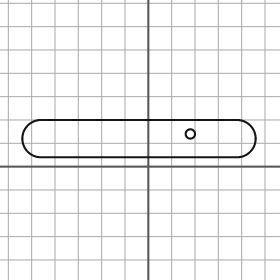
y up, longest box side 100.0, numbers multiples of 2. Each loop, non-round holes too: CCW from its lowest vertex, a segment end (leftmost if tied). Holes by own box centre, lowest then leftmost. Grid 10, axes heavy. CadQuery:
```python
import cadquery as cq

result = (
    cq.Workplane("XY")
    .moveTo(-46.0, 4.0)
    .lineTo(38.0, 4.0)
    .threePointArc((46.0, 12.0), (38.0, 20.0))
    .lineTo(-46.0, 20.0)
    .threePointArc((-54.0, 12.0), (-46.0, 4.0))
    .close()
    .moveTo(18.0, 14.0)
    .circle(2.0)
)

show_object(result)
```